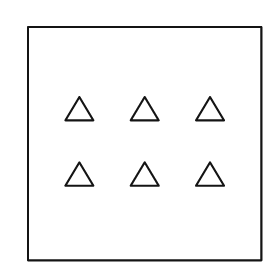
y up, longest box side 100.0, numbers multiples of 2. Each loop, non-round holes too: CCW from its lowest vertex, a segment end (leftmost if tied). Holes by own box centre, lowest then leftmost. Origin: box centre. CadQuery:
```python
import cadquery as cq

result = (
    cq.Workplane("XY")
    .moveTo(-50.0, -50.0)
    .lineTo(50.0, -50.0)
    .lineTo(50.0, 50.0)
    .lineTo(-50.0, 50.0)
    .close()
    .moveTo(-34.0, -18.0)
    .lineTo(-22.0, -18.0)
    .lineTo(-28.0, -8.0)
    .close()
    .moveTo(-6.0, -18.0)
    .lineTo(6.0, -18.0)
    .lineTo(0.0, -8.0)
    .close()
    .moveTo(22.0, -18.0)
    .lineTo(34.0, -18.0)
    .lineTo(28.0, -8.0)
    .close()
    .moveTo(-34.0, 10.0)
    .lineTo(-22.0, 10.0)
    .lineTo(-28.0, 20.0)
    .close()
    .moveTo(-6.0, 10.0)
    .lineTo(6.0, 10.0)
    .lineTo(0.0, 20.0)
    .close()
    .moveTo(22.0, 10.0)
    .lineTo(34.0, 10.0)
    .lineTo(28.0, 20.0)
    .close()
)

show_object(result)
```